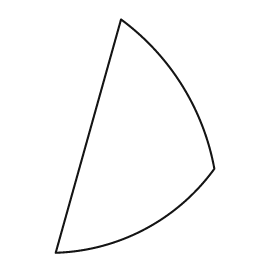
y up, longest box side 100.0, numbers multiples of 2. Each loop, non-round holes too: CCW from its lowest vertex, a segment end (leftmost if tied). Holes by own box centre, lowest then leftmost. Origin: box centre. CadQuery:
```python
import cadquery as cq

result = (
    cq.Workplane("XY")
    .moveTo(-34.0, -50.0)
    .threePointArc((4.0, -40.0), (34.0, -14.0))
    .threePointArc((20.0, 22.0), (-6.0, 50.0))
    .close()
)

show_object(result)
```